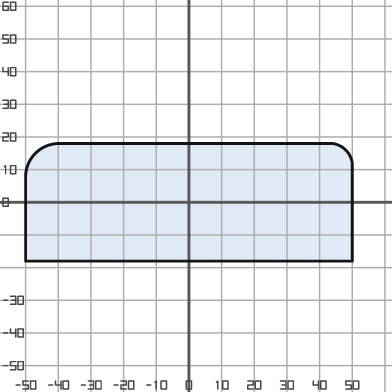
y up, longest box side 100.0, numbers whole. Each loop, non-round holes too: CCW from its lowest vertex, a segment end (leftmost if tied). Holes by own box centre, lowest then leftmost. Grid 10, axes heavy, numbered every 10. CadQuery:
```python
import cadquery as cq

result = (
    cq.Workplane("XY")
    .moveTo(-50.0, -18.0)
    .lineTo(50.0, -18.0)
    .lineTo(50.0, 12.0)
    .threePointArc((48.0, 16.0), (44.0, 18.0))
    .lineTo(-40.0, 18.0)
    .threePointArc((-47.0, 15.0), (-50.0, 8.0))
    .close()
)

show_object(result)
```